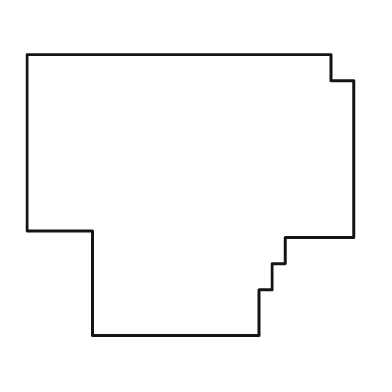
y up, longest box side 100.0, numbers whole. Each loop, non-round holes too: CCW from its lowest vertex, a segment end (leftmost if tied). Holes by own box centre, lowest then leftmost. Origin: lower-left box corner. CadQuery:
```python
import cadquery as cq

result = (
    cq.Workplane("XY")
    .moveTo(20.0, 0.0)
    .lineTo(71.0, 0.0)
    .lineTo(71.0, 14.0)
    .lineTo(75.0, 14.0)
    .lineTo(75.0, 22.0)
    .lineTo(79.0, 22.0)
    .lineTo(79.0, 30.0)
    .lineTo(100.0, 30.0)
    .lineTo(100.0, 78.0)
    .lineTo(93.0, 78.0)
    .lineTo(93.0, 86.0)
    .lineTo(0.0, 86.0)
    .lineTo(0.0, 32.0)
    .lineTo(20.0, 32.0)
    .close()
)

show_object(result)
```